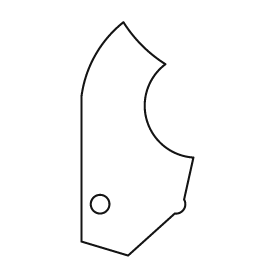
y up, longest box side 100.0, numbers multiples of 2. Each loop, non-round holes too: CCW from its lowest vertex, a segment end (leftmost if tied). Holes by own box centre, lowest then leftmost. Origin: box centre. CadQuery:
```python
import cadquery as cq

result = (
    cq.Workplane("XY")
    .moveTo(-4.0, -50.0)
    .lineTo(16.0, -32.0)
    .threePointArc((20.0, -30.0), (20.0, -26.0))
    .lineTo(24.0, -8.0)
    .threePointArc((4.0, 8.0), (12.0, 32.0))
    .threePointArc((2.0, 40.0), (-6.0, 50.0))
    .threePointArc((-18.0, 36.0), (-24.0, 18.0))
    .lineTo(-24.0, -44.0)
    .close()
    .moveTo(-16.0, -28.0)
    .circle(4.0)
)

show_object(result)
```